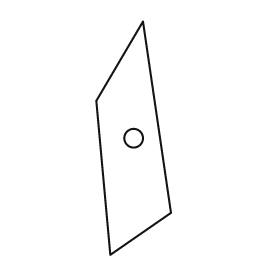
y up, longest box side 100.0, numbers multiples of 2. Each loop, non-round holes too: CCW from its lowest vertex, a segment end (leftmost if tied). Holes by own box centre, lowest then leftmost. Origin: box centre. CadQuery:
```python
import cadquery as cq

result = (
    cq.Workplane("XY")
    .moveTo(-10.0, -50.0)
    .lineTo(16.0, -32.0)
    .lineTo(4.0, 50.0)
    .lineTo(-16.0, 16.0)
    .close()
    .moveTo(0.0, 0.0)
    .circle(4.0)
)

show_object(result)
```